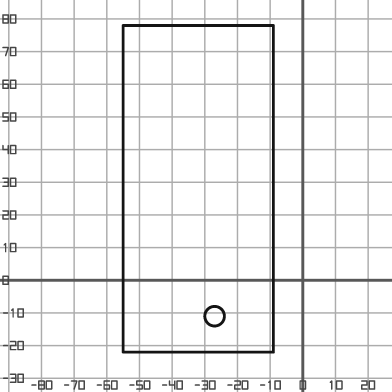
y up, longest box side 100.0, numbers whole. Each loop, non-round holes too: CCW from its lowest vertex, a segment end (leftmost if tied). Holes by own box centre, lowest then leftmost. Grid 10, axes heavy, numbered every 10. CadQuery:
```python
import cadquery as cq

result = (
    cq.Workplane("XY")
    .moveTo(-55.0, -22.0)
    .lineTo(-9.0, -22.0)
    .lineTo(-9.0, 78.0)
    .lineTo(-55.0, 78.0)
    .close()
    .moveTo(-27.0, -11.0)
    .circle(3.0)
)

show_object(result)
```